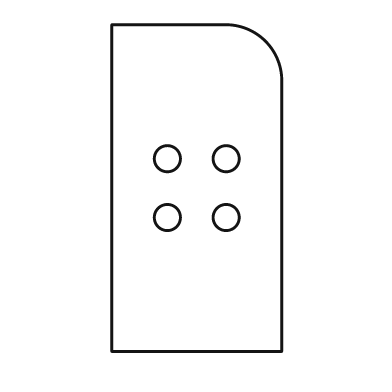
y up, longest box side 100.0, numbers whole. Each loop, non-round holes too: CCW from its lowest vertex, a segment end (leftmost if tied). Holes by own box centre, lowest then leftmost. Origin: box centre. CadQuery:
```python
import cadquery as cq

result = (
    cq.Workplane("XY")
    .moveTo(-26.0, -50.0)
    .lineTo(26.0, -50.0)
    .lineTo(26.0, 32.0)
    .threePointArc((21.0, 45.0), (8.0, 50.0))
    .lineTo(-26.0, 50.0)
    .close()
    .moveTo(-9.0, -9.0)
    .circle(4.0)
    .moveTo(9.0, -9.0)
    .circle(4.0)
    .moveTo(-9.0, 9.0)
    .circle(4.0)
    .moveTo(9.0, 9.0)
    .circle(4.0)
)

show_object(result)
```